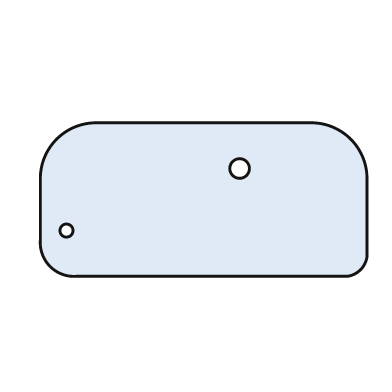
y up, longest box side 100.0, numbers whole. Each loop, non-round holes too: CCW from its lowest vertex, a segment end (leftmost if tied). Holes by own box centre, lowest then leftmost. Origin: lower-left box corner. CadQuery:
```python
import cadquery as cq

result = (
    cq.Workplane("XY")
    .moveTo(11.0, 0.0)
    .lineTo(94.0, 0.0)
    .threePointArc((98.0, 2.0), (100.0, 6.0))
    .lineTo(100.0, 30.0)
    .threePointArc((95.0, 42.0), (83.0, 47.0))
    .lineTo(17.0, 47.0)
    .threePointArc((5.0, 42.0), (0.0, 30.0))
    .lineTo(0.0, 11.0)
    .threePointArc((3.0, 3.0), (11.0, 0.0))
    .close()
    .moveTo(8.0, 14.0)
    .circle(2.0)
    .moveTo(61.0, 33.0)
    .circle(3.0)
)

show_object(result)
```